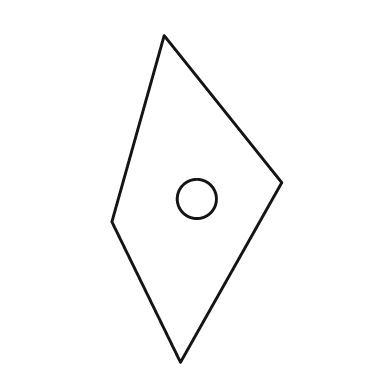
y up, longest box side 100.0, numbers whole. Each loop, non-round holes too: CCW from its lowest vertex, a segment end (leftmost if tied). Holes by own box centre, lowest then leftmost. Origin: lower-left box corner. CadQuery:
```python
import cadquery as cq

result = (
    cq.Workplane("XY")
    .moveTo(21.0, 0.0)
    .lineTo(52.0, 55.0)
    .lineTo(16.0, 100.0)
    .lineTo(0.0, 43.0)
    .close()
    .moveTo(26.0, 50.0)
    .circle(6.0)
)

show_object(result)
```